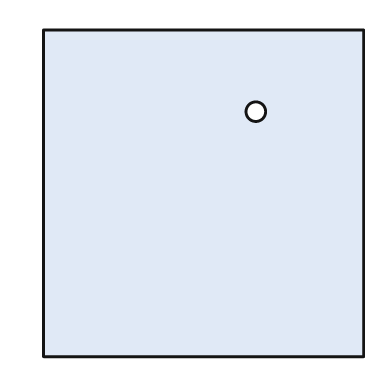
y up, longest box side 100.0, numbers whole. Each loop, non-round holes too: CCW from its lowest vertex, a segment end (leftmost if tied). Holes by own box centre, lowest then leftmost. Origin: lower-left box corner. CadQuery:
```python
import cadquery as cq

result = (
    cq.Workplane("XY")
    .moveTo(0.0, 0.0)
    .lineTo(98.0, 0.0)
    .lineTo(98.0, 100.0)
    .lineTo(0.0, 100.0)
    .close()
    .moveTo(65.0, 75.0)
    .circle(3.0)
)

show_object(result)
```